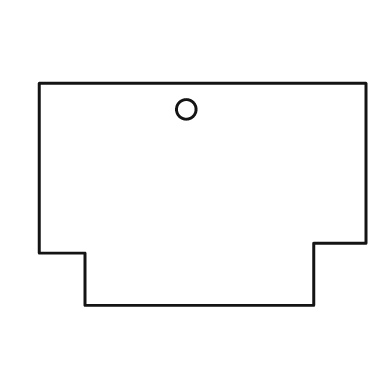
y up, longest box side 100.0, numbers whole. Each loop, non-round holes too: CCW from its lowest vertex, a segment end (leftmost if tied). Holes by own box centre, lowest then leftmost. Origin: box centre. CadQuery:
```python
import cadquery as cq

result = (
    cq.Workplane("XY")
    .moveTo(-36.0, -34.0)
    .lineTo(34.0, -34.0)
    .lineTo(34.0, -15.0)
    .lineTo(50.0, -15.0)
    .lineTo(50.0, 34.0)
    .lineTo(-50.0, 34.0)
    .lineTo(-50.0, -18.0)
    .lineTo(-36.0, -18.0)
    .close()
    .moveTo(-5.0, 26.0)
    .circle(3.0)
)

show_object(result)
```